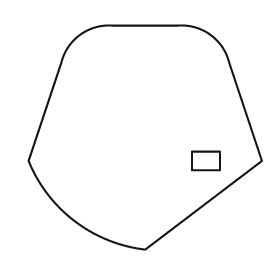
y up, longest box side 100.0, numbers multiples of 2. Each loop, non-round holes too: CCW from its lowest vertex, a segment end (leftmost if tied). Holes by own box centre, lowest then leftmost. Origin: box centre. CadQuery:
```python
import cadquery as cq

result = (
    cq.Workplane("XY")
    .moveTo(0.0, -48.0)
    .lineTo(50.0, -10.0)
    .lineTo(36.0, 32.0)
    .threePointArc((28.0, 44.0), (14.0, 48.0))
    .lineTo(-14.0, 48.0)
    .threePointArc((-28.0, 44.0), (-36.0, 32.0))
    .lineTo(-50.0, -10.0)
    .threePointArc((-30.0, -36.0), (0.0, -48.0))
    .close()
    .moveTo(20.0, -14.0)
    .lineTo(32.0, -14.0)
    .lineTo(32.0, -6.0)
    .lineTo(20.0, -6.0)
    .close()
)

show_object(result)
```